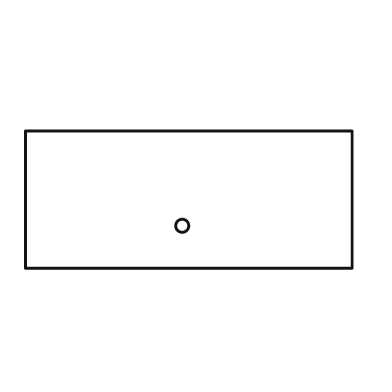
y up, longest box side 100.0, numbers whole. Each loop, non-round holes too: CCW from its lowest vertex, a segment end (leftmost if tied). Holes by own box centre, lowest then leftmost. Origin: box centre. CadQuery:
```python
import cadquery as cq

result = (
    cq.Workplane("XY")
    .moveTo(-50.0, -21.0)
    .lineTo(50.0, -21.0)
    .lineTo(50.0, 21.0)
    .lineTo(-50.0, 21.0)
    .close()
    .moveTo(-2.0, -8.0)
    .circle(2.0)
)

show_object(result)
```